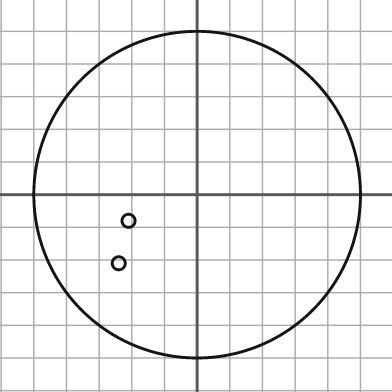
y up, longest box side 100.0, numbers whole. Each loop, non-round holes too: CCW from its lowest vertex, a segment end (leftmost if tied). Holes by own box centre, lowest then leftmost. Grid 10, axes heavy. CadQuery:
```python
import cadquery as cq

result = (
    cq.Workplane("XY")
    .moveTo(0.0, 0.0)
    .circle(50.0)
    .moveTo(-24.0, -21.0)
    .circle(2.0)
    .moveTo(-21.0, -8.0)
    .circle(2.0)
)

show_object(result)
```